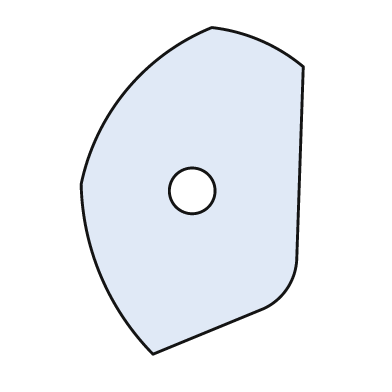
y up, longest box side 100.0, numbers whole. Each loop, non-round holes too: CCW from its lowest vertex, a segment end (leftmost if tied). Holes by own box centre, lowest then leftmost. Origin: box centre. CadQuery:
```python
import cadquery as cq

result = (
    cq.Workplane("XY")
    .moveTo(-12.0, -50.0)
    .lineTo(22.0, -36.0)
    .threePointArc((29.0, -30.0), (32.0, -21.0))
    .lineTo(34.0, 38.0)
    .threePointArc((21.0, 46.0), (6.0, 50.0))
    .threePointArc((-20.0, 31.0), (-34.0, 2.0))
    .threePointArc((-28.0, -26.0), (-12.0, -50.0))
    .close()
    .moveTo(0.0, 0.0)
    .circle(7.0)
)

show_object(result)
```